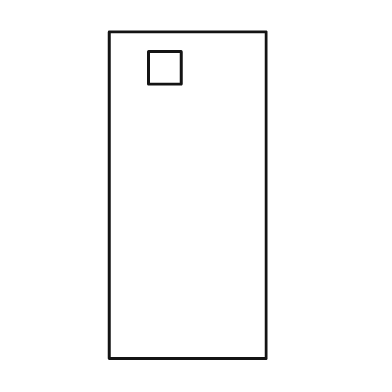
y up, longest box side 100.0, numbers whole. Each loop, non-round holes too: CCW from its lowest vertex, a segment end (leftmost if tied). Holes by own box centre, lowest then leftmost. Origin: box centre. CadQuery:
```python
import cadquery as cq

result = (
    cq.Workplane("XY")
    .moveTo(-24.0, -50.0)
    .lineTo(24.0, -50.0)
    .lineTo(24.0, 50.0)
    .lineTo(-24.0, 50.0)
    .close()
    .moveTo(-12.0, 34.0)
    .lineTo(-2.0, 34.0)
    .lineTo(-2.0, 44.0)
    .lineTo(-12.0, 44.0)
    .close()
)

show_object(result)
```